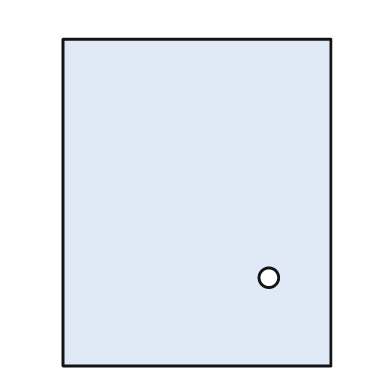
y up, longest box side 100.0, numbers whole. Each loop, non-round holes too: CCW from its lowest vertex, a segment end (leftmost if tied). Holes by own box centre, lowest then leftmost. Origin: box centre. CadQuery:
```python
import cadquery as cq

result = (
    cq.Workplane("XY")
    .moveTo(-41.0, -50.0)
    .lineTo(41.0, -50.0)
    .lineTo(41.0, 50.0)
    .lineTo(-41.0, 50.0)
    .close()
    .moveTo(22.0, -23.0)
    .circle(3.0)
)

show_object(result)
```